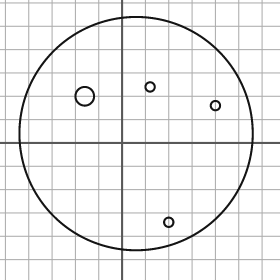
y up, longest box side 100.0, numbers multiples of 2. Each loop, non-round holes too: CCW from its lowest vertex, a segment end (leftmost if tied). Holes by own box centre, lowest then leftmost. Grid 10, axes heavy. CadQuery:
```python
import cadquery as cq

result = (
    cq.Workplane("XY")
    .moveTo(6.0, 4.0)
    .circle(50.0)
    .moveTo(20.0, -34.0)
    .circle(2.0)
    .moveTo(40.0, 16.0)
    .circle(2.0)
    .moveTo(-16.0, 20.0)
    .circle(4.0)
    .moveTo(12.0, 24.0)
    .circle(2.0)
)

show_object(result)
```